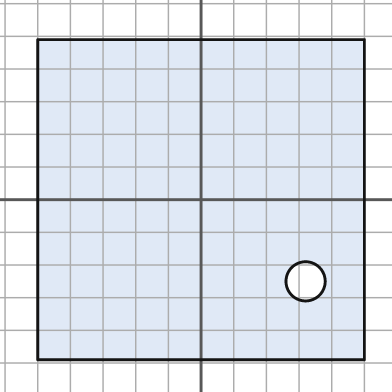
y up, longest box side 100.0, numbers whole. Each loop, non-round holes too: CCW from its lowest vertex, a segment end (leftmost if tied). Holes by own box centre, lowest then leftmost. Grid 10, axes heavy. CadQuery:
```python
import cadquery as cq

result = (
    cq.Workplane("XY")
    .moveTo(-50.0, -49.0)
    .lineTo(50.0, -49.0)
    .lineTo(50.0, 49.0)
    .lineTo(-50.0, 49.0)
    .close()
    .moveTo(32.0, -25.0)
    .circle(6.0)
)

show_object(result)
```